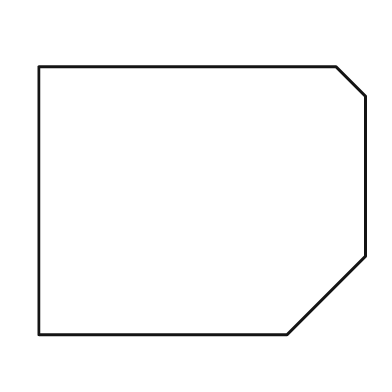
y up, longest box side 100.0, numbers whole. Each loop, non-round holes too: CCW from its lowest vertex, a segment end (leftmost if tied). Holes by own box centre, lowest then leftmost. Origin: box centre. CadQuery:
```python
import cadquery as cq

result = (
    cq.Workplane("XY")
    .moveTo(-50.0, -41.0)
    .lineTo(26.0, -41.0)
    .lineTo(50.0, -17.0)
    .lineTo(50.0, 32.0)
    .lineTo(41.0, 41.0)
    .lineTo(-50.0, 41.0)
    .close()
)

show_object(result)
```